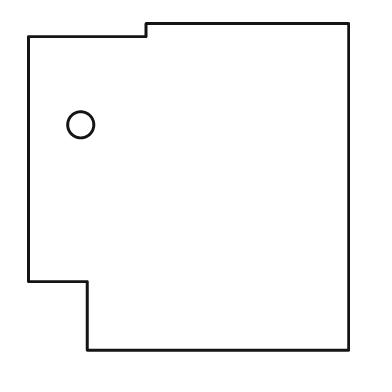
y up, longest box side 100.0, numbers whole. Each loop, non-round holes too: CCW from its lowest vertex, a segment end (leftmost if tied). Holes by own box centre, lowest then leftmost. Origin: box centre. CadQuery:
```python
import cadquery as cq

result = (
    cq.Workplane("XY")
    .moveTo(-31.0, -50.0)
    .lineTo(49.0, -50.0)
    .lineTo(49.0, 50.0)
    .lineTo(-13.0, 50.0)
    .lineTo(-13.0, 46.0)
    .lineTo(-49.0, 46.0)
    .lineTo(-49.0, -29.0)
    .lineTo(-31.0, -29.0)
    .close()
    .moveTo(-33.0, 19.0)
    .circle(4.0)
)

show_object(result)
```